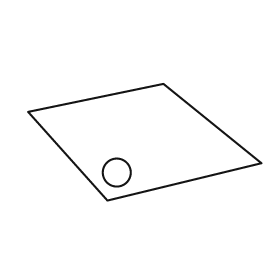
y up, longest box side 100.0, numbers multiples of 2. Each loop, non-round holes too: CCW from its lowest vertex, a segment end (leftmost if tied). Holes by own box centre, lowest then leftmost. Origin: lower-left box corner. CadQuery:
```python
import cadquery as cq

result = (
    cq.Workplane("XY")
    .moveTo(34.0, 0.0)
    .lineTo(100.0, 16.0)
    .lineTo(58.0, 50.0)
    .lineTo(0.0, 38.0)
    .close()
    .moveTo(38.0, 12.0)
    .circle(6.0)
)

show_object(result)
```